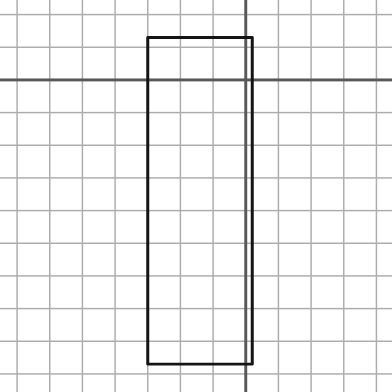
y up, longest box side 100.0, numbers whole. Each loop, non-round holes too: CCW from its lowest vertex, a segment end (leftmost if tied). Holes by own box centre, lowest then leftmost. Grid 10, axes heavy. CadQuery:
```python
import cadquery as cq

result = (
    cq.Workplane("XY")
    .moveTo(-30.0, -87.0)
    .lineTo(2.0, -87.0)
    .lineTo(2.0, 13.0)
    .lineTo(-30.0, 13.0)
    .close()
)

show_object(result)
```